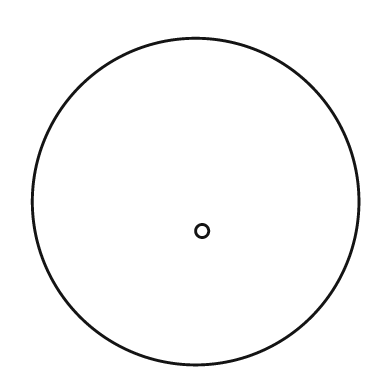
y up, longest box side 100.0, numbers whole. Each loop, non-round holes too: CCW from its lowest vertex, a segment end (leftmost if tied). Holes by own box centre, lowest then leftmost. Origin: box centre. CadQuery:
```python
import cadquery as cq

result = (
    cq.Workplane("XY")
    .moveTo(0.0, 0.0)
    .circle(50.0)
    .moveTo(2.0, -9.0)
    .circle(2.0)
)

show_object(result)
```